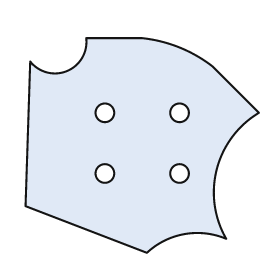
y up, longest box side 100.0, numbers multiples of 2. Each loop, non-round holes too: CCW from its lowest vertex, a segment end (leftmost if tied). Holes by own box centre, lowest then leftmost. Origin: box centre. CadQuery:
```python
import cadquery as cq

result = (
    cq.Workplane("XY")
    .moveTo(2.0, -46.0)
    .threePointArc((18.0, -38.0), (36.0, -40.0))
    .threePointArc((32.0, -10.0), (50.0, 14.0))
    .lineTo(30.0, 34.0)
    .threePointArc((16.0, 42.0), (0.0, 46.0))
    .lineTo(-24.0, 46.0)
    .threePointArc((-32.0, 32.0), (-48.0, 36.0))
    .lineTo(-50.0, -26.0)
    .close()
    .moveTo(-16.0, -12.0)
    .circle(4.0)
    .moveTo(16.0, -12.0)
    .circle(4.0)
    .moveTo(-16.0, 14.0)
    .circle(4.0)
    .moveTo(16.0, 14.0)
    .circle(4.0)
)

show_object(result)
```